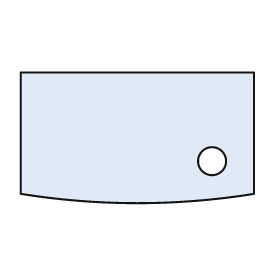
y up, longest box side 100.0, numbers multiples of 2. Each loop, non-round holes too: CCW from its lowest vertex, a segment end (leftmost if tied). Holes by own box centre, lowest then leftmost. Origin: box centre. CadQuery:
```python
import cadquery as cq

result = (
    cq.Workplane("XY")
    .moveTo(-50.0, -24.0)
    .threePointArc((0.0, -28.0), (50.0, -24.0))
    .lineTo(50.0, 28.0)
    .lineTo(-50.0, 28.0)
    .close()
    .moveTo(32.0, -10.0)
    .circle(6.0)
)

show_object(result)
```